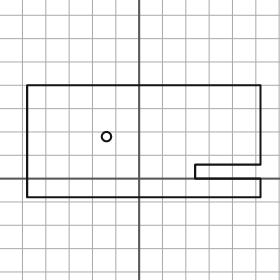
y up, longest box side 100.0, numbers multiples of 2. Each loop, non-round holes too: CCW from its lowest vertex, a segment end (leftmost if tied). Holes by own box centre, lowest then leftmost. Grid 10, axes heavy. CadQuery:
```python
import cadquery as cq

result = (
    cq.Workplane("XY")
    .moveTo(-48.0, -8.0)
    .lineTo(52.0, -8.0)
    .lineTo(52.0, 0.0)
    .lineTo(24.0, 0.0)
    .lineTo(24.0, 6.0)
    .lineTo(52.0, 6.0)
    .lineTo(52.0, 40.0)
    .lineTo(-48.0, 40.0)
    .close()
    .moveTo(-14.0, 18.0)
    .circle(2.0)
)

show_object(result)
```